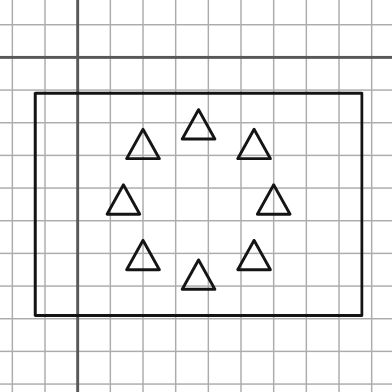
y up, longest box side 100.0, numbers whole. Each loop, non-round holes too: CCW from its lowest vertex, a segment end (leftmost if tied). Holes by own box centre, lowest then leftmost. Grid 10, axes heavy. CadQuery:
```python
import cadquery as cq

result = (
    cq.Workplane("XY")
    .moveTo(-13.0, -79.0)
    .lineTo(87.0, -79.0)
    .lineTo(87.0, -11.0)
    .lineTo(-13.0, -11.0)
    .close()
    .moveTo(32.0, -71.0)
    .lineTo(42.0, -71.0)
    .lineTo(37.0, -62.0)
    .close()
    .moveTo(15.0, -65.0)
    .lineTo(25.0, -65.0)
    .lineTo(20.0, -56.0)
    .close()
    .moveTo(49.0, -65.0)
    .lineTo(59.0, -65.0)
    .lineTo(54.0, -56.0)
    .close()
    .moveTo(9.0, -48.0)
    .lineTo(19.0, -48.0)
    .lineTo(14.0, -39.0)
    .close()
    .moveTo(55.0, -48.0)
    .lineTo(65.0, -48.0)
    .lineTo(60.0, -39.0)
    .close()
    .moveTo(15.0, -31.0)
    .lineTo(25.0, -31.0)
    .lineTo(20.0, -22.0)
    .close()
    .moveTo(49.0, -31.0)
    .lineTo(59.0, -31.0)
    .lineTo(54.0, -22.0)
    .close()
    .moveTo(32.0, -25.0)
    .lineTo(42.0, -25.0)
    .lineTo(37.0, -16.0)
    .close()
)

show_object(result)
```